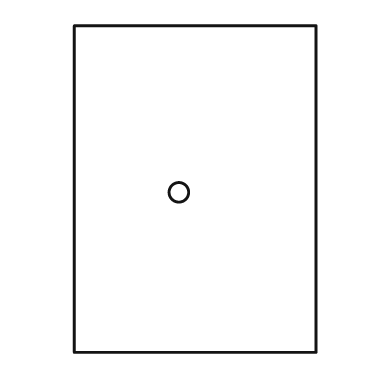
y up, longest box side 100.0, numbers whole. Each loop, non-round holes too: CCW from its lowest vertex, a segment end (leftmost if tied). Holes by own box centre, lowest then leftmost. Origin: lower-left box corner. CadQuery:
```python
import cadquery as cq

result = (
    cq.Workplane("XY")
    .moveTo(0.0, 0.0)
    .lineTo(74.0, 0.0)
    .lineTo(74.0, 100.0)
    .lineTo(0.0, 100.0)
    .close()
    .moveTo(32.0, 49.0)
    .circle(3.0)
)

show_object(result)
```